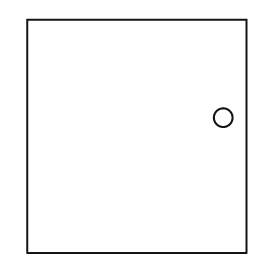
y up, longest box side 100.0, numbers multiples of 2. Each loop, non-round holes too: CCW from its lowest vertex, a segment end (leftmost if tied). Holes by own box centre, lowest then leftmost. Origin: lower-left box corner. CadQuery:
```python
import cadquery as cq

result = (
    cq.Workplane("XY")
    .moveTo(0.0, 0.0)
    .lineTo(94.0, 0.0)
    .lineTo(94.0, 100.0)
    .lineTo(0.0, 100.0)
    .close()
    .moveTo(84.0, 58.0)
    .circle(4.0)
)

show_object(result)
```